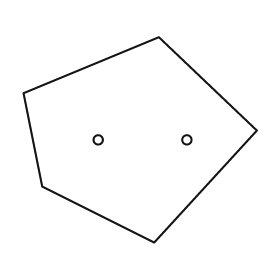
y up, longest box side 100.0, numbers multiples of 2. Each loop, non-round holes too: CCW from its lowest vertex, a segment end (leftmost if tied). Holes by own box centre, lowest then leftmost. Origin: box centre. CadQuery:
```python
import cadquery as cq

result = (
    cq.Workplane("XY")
    .moveTo(6.0, -44.0)
    .lineTo(50.0, 4.0)
    .lineTo(8.0, 44.0)
    .lineTo(-50.0, 20.0)
    .lineTo(-42.0, -20.0)
    .close()
    .moveTo(-18.0, 0.0)
    .circle(2.0)
    .moveTo(20.0, 0.0)
    .circle(2.0)
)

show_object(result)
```